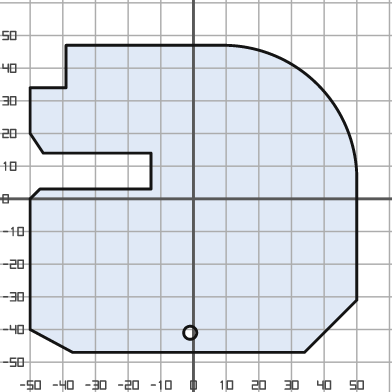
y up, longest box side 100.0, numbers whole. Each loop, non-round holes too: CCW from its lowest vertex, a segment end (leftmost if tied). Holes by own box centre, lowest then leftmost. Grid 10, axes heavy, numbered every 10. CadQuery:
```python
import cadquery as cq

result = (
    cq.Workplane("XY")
    .moveTo(-37.0, -47.0)
    .lineTo(34.0, -47.0)
    .lineTo(50.0, -31.0)
    .lineTo(50.0, 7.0)
    .threePointArc((38.0, 35.0), (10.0, 47.0))
    .lineTo(-39.0, 47.0)
    .lineTo(-39.0, 34.0)
    .lineTo(-50.0, 34.0)
    .lineTo(-50.0, 20.0)
    .lineTo(-46.0, 14.0)
    .lineTo(-13.0, 14.0)
    .lineTo(-13.0, 3.0)
    .lineTo(-47.0, 3.0)
    .lineTo(-50.0, 0.0)
    .lineTo(-50.0, -40.0)
    .close()
    .moveTo(-1.0, -41.0)
    .circle(2.0)
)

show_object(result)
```